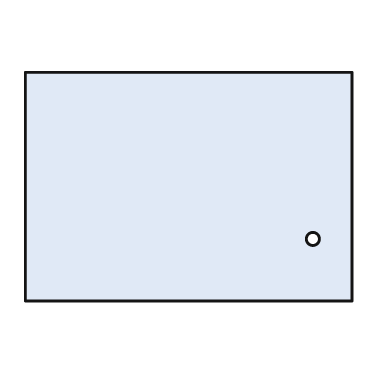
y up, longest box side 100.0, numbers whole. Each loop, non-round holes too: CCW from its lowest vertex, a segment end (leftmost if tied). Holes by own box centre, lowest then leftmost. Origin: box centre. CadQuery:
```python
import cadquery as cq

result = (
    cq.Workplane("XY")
    .moveTo(-50.0, -35.0)
    .lineTo(50.0, -35.0)
    .lineTo(50.0, 35.0)
    .lineTo(-50.0, 35.0)
    .close()
    .moveTo(38.0, -16.0)
    .circle(2.0)
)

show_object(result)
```